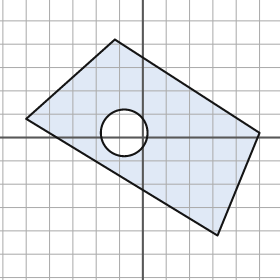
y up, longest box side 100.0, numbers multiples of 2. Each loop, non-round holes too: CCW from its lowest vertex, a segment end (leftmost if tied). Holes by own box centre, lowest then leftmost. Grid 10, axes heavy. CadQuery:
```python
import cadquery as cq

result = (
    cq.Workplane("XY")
    .moveTo(32.0, -42.0)
    .lineTo(50.0, 2.0)
    .lineTo(-12.0, 42.0)
    .lineTo(-50.0, 8.0)
    .close()
    .moveTo(-8.0, 2.0)
    .circle(10.0)
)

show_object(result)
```